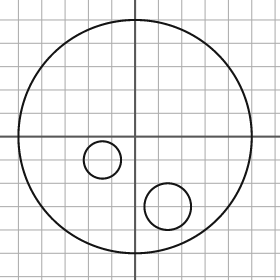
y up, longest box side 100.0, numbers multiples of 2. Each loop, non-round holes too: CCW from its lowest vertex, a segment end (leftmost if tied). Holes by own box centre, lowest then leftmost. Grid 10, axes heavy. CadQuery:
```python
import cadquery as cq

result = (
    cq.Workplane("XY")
    .moveTo(0.0, 0.0)
    .circle(50.0)
    .moveTo(14.0, -30.0)
    .circle(10.0)
    .moveTo(-14.0, -10.0)
    .circle(8.0)
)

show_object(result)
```